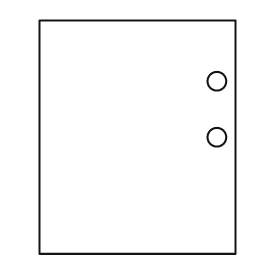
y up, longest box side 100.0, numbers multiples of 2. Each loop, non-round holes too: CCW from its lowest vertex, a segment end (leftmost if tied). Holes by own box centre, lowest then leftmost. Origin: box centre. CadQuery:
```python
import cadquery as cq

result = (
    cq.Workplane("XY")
    .moveTo(-42.0, -50.0)
    .lineTo(42.0, -50.0)
    .lineTo(42.0, 50.0)
    .lineTo(-42.0, 50.0)
    .close()
    .moveTo(34.0, 0.0)
    .circle(4.0)
    .moveTo(34.0, 24.0)
    .circle(4.0)
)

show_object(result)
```